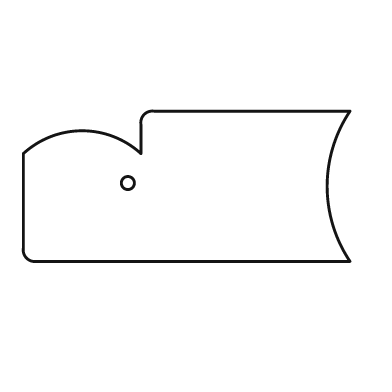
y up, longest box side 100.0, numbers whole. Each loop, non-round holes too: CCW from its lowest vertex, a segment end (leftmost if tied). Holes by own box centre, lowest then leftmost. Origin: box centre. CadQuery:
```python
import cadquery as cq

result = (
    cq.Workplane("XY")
    .moveTo(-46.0, -23.0)
    .lineTo(50.0, -23.0)
    .threePointArc((43.0, 0.0), (50.0, 23.0))
    .lineTo(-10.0, 23.0)
    .threePointArc((-13.0, 22.0), (-14.0, 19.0))
    .lineTo(-14.0, 10.0)
    .threePointArc((-32.0, 17.0), (-50.0, 10.0))
    .lineTo(-50.0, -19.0)
    .threePointArc((-49.0, -22.0), (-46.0, -23.0))
    .close()
    .moveTo(-18.0, 1.0)
    .circle(2.0)
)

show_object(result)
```